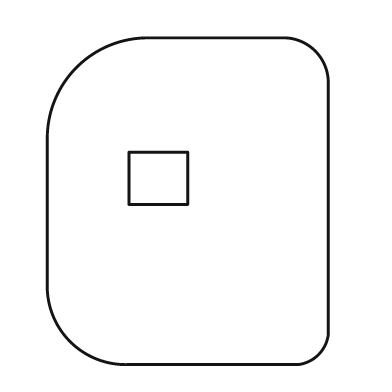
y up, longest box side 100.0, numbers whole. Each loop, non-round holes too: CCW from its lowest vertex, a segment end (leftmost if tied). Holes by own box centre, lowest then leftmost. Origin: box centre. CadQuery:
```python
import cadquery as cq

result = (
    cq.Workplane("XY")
    .moveTo(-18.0, -50.0)
    .lineTo(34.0, -50.0)
    .threePointArc((40.0, -47.0), (43.0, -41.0))
    .lineTo(43.0, 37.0)
    .threePointArc((39.0, 46.0), (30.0, 50.0))
    .lineTo(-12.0, 50.0)
    .threePointArc((-34.0, 41.0), (-43.0, 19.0))
    .lineTo(-43.0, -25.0)
    .threePointArc((-36.0, -43.0), (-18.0, -50.0))
    .close()
    .moveTo(-18.0, -1.0)
    .lineTo(0.0, -1.0)
    .lineTo(0.0, 15.0)
    .lineTo(-18.0, 15.0)
    .close()
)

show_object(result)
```